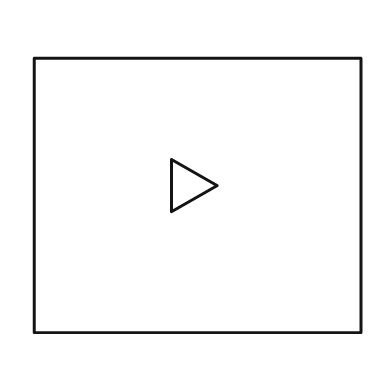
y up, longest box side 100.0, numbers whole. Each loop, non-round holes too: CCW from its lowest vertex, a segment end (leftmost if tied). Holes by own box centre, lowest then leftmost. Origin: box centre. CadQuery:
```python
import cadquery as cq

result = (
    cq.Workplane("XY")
    .moveTo(-50.0, -42.0)
    .lineTo(50.0, -42.0)
    .lineTo(50.0, 42.0)
    .lineTo(-50.0, 42.0)
    .close()
    .moveTo(-8.0, -5.0)
    .lineTo(6.0, 3.0)
    .lineTo(-8.0, 11.0)
    .close()
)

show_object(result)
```